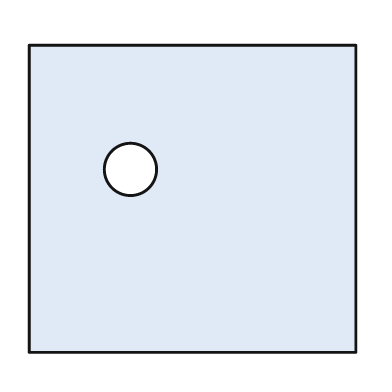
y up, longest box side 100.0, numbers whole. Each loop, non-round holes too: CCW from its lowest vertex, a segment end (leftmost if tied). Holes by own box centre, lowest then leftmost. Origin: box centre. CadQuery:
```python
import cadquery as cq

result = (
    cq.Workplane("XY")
    .moveTo(-50.0, -47.0)
    .lineTo(50.0, -47.0)
    .lineTo(50.0, 47.0)
    .lineTo(-50.0, 47.0)
    .close()
    .moveTo(-19.0, 9.0)
    .circle(8.0)
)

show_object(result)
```